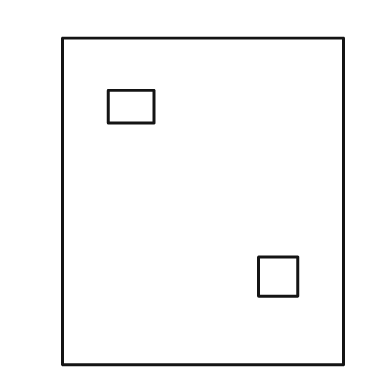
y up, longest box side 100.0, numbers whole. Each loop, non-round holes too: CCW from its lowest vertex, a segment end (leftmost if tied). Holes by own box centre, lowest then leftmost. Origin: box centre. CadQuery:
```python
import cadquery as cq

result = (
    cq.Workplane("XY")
    .moveTo(-43.0, -50.0)
    .lineTo(43.0, -50.0)
    .lineTo(43.0, 50.0)
    .lineTo(-43.0, 50.0)
    .close()
    .moveTo(17.0, -29.0)
    .lineTo(29.0, -29.0)
    .lineTo(29.0, -17.0)
    .lineTo(17.0, -17.0)
    .close()
    .moveTo(-29.0, 24.0)
    .lineTo(-15.0, 24.0)
    .lineTo(-15.0, 34.0)
    .lineTo(-29.0, 34.0)
    .close()
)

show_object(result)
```